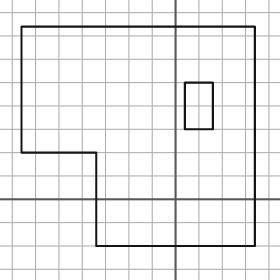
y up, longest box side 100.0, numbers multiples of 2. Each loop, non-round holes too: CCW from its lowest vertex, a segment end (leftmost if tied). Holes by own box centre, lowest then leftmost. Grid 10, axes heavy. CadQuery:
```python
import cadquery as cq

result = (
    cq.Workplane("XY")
    .moveTo(-34.0, -20.0)
    .lineTo(34.0, -20.0)
    .lineTo(34.0, 74.0)
    .lineTo(-66.0, 74.0)
    .lineTo(-66.0, 20.0)
    .lineTo(-34.0, 20.0)
    .close()
    .moveTo(4.0, 30.0)
    .lineTo(16.0, 30.0)
    .lineTo(16.0, 50.0)
    .lineTo(4.0, 50.0)
    .close()
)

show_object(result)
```